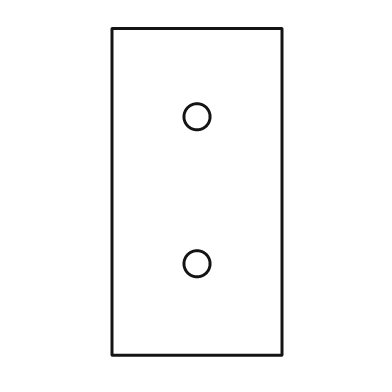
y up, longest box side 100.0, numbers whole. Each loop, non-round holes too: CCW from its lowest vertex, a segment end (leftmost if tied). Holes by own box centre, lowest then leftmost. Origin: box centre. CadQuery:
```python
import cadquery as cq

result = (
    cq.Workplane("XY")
    .moveTo(-26.0, -50.0)
    .lineTo(26.0, -50.0)
    .lineTo(26.0, 50.0)
    .lineTo(-26.0, 50.0)
    .close()
    .moveTo(0.0, -22.0)
    .circle(4.0)
    .moveTo(0.0, 23.0)
    .circle(4.0)
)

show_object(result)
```